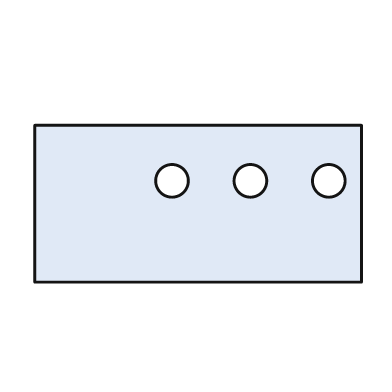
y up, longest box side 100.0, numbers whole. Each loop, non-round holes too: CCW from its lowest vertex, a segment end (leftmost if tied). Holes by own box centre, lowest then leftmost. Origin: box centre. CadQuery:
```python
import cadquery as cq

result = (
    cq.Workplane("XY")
    .moveTo(-50.0, -24.0)
    .lineTo(50.0, -24.0)
    .lineTo(50.0, 24.0)
    .lineTo(-50.0, 24.0)
    .close()
    .moveTo(-8.0, 7.0)
    .circle(5.0)
    .moveTo(16.0, 7.0)
    .circle(5.0)
    .moveTo(40.0, 7.0)
    .circle(5.0)
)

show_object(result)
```